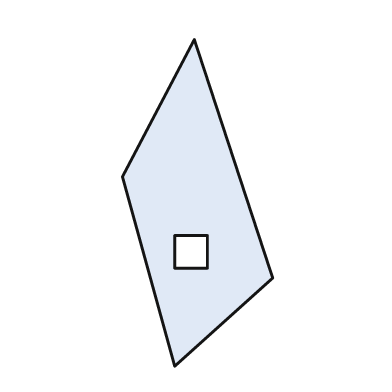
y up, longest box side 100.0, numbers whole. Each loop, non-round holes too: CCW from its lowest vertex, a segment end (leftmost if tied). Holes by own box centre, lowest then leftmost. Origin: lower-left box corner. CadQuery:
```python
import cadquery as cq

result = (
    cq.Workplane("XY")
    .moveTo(16.0, 0.0)
    .lineTo(46.0, 27.0)
    .lineTo(22.0, 100.0)
    .lineTo(0.0, 58.0)
    .close()
    .moveTo(16.0, 30.0)
    .lineTo(26.0, 30.0)
    .lineTo(26.0, 40.0)
    .lineTo(16.0, 40.0)
    .close()
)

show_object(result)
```